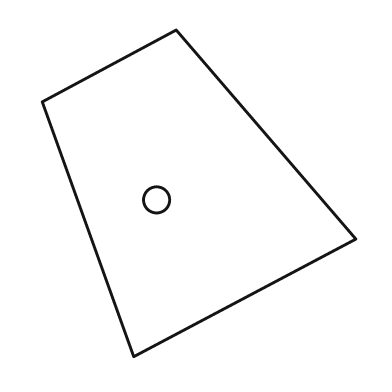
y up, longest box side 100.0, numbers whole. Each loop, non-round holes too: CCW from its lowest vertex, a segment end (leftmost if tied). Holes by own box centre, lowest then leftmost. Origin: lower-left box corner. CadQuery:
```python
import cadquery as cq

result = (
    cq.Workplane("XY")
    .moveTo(28.0, 0.0)
    .lineTo(96.0, 36.0)
    .lineTo(41.0, 100.0)
    .lineTo(0.0, 78.0)
    .close()
    .moveTo(35.0, 48.0)
    .circle(4.0)
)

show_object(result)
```